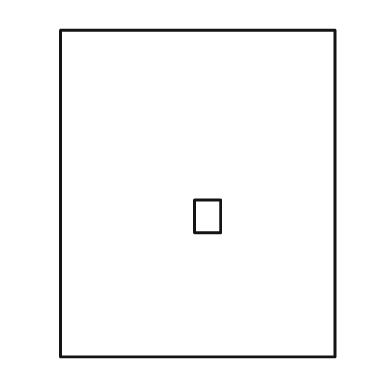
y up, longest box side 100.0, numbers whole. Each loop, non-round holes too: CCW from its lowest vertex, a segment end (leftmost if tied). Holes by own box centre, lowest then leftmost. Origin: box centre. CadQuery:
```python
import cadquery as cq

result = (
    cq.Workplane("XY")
    .moveTo(-42.0, -50.0)
    .lineTo(42.0, -50.0)
    .lineTo(42.0, 50.0)
    .lineTo(-42.0, 50.0)
    .close()
    .moveTo(-1.0, -12.0)
    .lineTo(7.0, -12.0)
    .lineTo(7.0, -2.0)
    .lineTo(-1.0, -2.0)
    .close()
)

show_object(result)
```